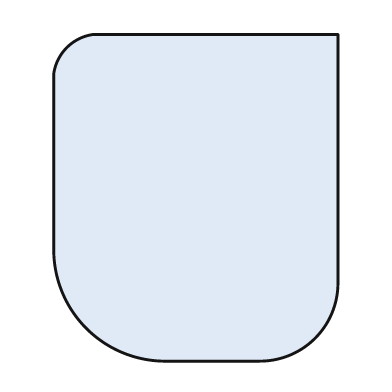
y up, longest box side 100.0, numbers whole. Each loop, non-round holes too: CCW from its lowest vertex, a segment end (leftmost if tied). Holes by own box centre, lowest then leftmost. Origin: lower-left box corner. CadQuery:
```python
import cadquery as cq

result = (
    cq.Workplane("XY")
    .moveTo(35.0, 0.0)
    .lineTo(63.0, 0.0)
    .threePointArc((80.0, 7.0), (87.0, 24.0))
    .lineTo(87.0, 100.0)
    .lineTo(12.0, 100.0)
    .threePointArc((4.0, 96.0), (0.0, 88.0))
    .lineTo(0.0, 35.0)
    .threePointArc((10.0, 10.0), (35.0, 0.0))
    .close()
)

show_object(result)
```